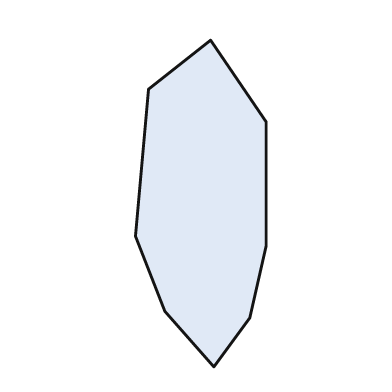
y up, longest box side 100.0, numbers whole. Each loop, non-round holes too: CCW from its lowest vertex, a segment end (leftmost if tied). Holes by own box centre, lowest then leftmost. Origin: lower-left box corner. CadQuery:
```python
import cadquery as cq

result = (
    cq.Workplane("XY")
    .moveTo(24.0, 0.0)
    .lineTo(35.0, 15.0)
    .lineTo(40.0, 37.0)
    .lineTo(40.0, 75.0)
    .lineTo(23.0, 100.0)
    .lineTo(4.0, 85.0)
    .lineTo(0.0, 40.0)
    .lineTo(9.0, 17.0)
    .close()
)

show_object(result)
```